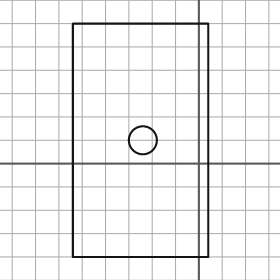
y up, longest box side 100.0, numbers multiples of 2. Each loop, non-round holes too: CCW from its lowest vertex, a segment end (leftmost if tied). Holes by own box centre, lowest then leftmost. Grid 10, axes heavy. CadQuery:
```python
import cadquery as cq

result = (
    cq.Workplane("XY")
    .moveTo(-54.0, -40.0)
    .lineTo(4.0, -40.0)
    .lineTo(4.0, 60.0)
    .lineTo(-54.0, 60.0)
    .close()
    .moveTo(-24.0, 10.0)
    .circle(6.0)
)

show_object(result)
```